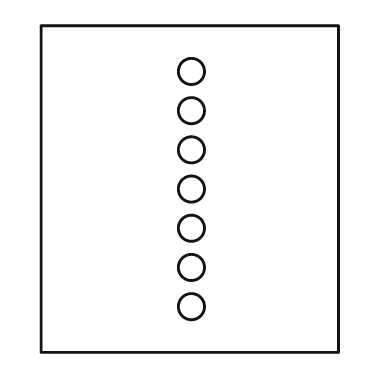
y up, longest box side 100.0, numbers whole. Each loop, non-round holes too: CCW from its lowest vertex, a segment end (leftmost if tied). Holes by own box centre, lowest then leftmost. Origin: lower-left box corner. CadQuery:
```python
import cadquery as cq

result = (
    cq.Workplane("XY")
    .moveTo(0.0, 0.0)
    .lineTo(91.0, 0.0)
    .lineTo(91.0, 100.0)
    .lineTo(0.0, 100.0)
    .close()
    .moveTo(46.0, 14.0)
    .circle(4.0)
    .moveTo(46.0, 26.0)
    .circle(4.0)
    .moveTo(46.0, 38.0)
    .circle(4.0)
    .moveTo(46.0, 50.0)
    .circle(4.0)
    .moveTo(46.0, 62.0)
    .circle(4.0)
    .moveTo(46.0, 74.0)
    .circle(4.0)
    .moveTo(46.0, 86.0)
    .circle(4.0)
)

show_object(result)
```